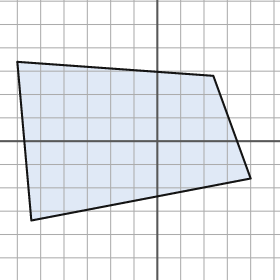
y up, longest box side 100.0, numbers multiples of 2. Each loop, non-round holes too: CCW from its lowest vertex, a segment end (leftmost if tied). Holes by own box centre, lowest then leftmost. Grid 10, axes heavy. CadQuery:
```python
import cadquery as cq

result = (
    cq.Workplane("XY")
    .moveTo(-54.0, -34.0)
    .lineTo(40.0, -16.0)
    .lineTo(24.0, 28.0)
    .lineTo(-60.0, 34.0)
    .close()
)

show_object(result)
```